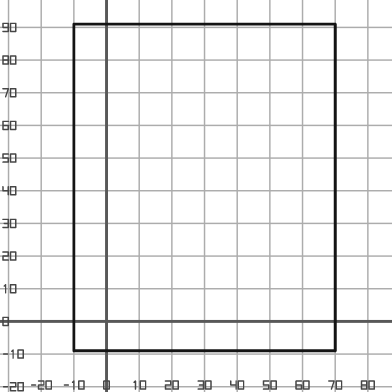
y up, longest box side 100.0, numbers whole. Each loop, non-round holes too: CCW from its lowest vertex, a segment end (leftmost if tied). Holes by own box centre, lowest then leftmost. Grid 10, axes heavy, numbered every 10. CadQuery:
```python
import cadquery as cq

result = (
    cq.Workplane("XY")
    .moveTo(-10.0, -9.0)
    .lineTo(70.0, -9.0)
    .lineTo(70.0, 91.0)
    .lineTo(-10.0, 91.0)
    .close()
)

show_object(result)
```